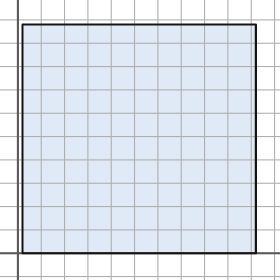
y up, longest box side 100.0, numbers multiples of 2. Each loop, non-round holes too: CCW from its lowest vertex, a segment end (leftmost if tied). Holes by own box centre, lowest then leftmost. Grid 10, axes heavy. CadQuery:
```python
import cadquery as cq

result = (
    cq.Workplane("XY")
    .moveTo(2.0, 0.0)
    .lineTo(102.0, 0.0)
    .lineTo(102.0, 98.0)
    .lineTo(2.0, 98.0)
    .close()
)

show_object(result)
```